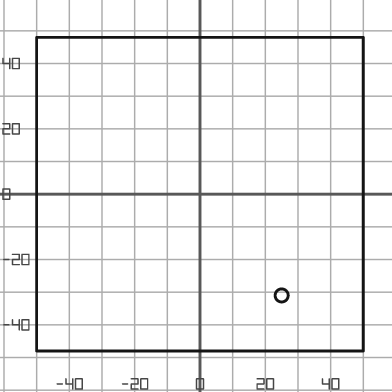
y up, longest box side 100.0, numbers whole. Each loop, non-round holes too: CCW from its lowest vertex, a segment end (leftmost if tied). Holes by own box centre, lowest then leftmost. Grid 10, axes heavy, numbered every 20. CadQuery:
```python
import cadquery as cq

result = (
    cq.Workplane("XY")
    .moveTo(-50.0, -48.0)
    .lineTo(50.0, -48.0)
    .lineTo(50.0, 48.0)
    .lineTo(-50.0, 48.0)
    .close()
    .moveTo(25.0, -31.0)
    .circle(2.0)
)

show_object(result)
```